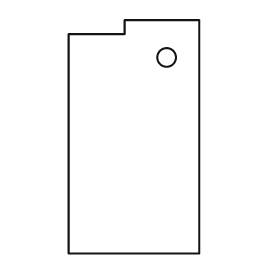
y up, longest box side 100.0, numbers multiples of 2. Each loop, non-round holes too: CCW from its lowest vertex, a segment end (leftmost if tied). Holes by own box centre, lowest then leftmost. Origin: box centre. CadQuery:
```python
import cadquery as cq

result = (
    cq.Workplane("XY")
    .moveTo(-28.0, -50.0)
    .lineTo(28.0, -50.0)
    .lineTo(28.0, 50.0)
    .lineTo(-4.0, 50.0)
    .lineTo(-4.0, 44.0)
    .lineTo(-28.0, 44.0)
    .close()
    .moveTo(14.0, 34.0)
    .circle(4.0)
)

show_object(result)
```